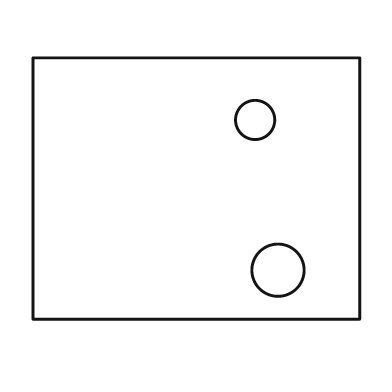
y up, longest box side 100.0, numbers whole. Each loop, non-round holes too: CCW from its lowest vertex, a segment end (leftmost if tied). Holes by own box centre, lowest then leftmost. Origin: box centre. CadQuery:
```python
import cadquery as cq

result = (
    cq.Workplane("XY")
    .moveTo(-50.0, -40.0)
    .lineTo(50.0, -40.0)
    .lineTo(50.0, 40.0)
    .lineTo(-50.0, 40.0)
    .close()
    .moveTo(25.0, -25.0)
    .circle(8.0)
    .moveTo(18.0, 21.0)
    .circle(6.0)
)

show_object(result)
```